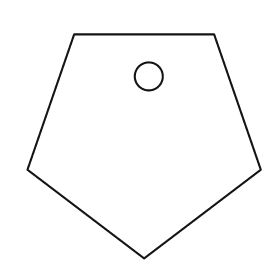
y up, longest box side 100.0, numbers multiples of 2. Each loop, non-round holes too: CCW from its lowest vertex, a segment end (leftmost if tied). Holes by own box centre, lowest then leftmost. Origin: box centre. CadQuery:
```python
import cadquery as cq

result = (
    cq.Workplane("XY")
    .moveTo(0.0, -48.0)
    .lineTo(50.0, -10.0)
    .lineTo(30.0, 48.0)
    .lineTo(-30.0, 48.0)
    .lineTo(-50.0, -10.0)
    .close()
    .moveTo(2.0, 30.0)
    .circle(6.0)
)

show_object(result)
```